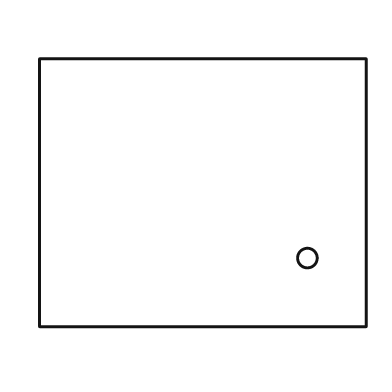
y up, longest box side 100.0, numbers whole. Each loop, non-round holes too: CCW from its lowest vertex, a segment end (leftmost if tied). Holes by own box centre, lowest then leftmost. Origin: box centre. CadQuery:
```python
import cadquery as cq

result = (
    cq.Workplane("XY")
    .moveTo(-50.0, -41.0)
    .lineTo(50.0, -41.0)
    .lineTo(50.0, 41.0)
    .lineTo(-50.0, 41.0)
    .close()
    .moveTo(32.0, -20.0)
    .circle(3.0)
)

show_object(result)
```